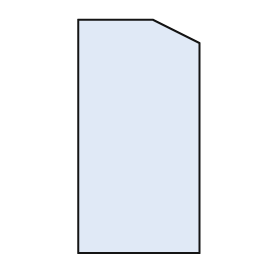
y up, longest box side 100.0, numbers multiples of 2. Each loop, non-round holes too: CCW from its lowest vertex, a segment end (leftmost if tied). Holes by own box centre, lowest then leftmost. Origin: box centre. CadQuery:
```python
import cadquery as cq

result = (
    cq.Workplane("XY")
    .moveTo(-26.0, -50.0)
    .lineTo(26.0, -50.0)
    .lineTo(26.0, 40.0)
    .lineTo(6.0, 50.0)
    .lineTo(-26.0, 50.0)
    .close()
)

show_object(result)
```